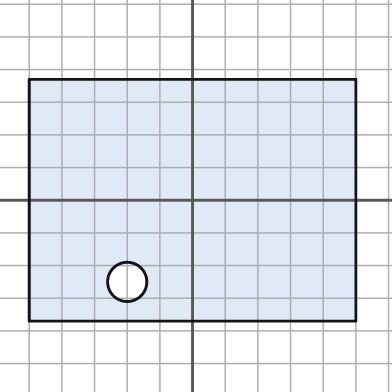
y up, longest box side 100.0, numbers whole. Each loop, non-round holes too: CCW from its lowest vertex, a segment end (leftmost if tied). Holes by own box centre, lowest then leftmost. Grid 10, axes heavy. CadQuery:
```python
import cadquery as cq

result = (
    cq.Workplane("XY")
    .moveTo(-50.0, -37.0)
    .lineTo(50.0, -37.0)
    .lineTo(50.0, 37.0)
    .lineTo(-50.0, 37.0)
    .close()
    .moveTo(-20.0, -25.0)
    .circle(6.0)
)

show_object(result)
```